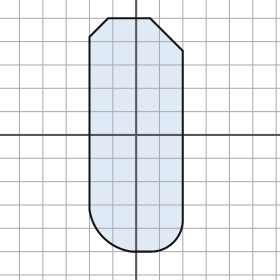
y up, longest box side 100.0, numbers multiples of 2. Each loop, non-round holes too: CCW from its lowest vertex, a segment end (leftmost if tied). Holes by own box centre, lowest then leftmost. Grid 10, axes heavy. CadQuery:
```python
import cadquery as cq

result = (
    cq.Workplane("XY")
    .moveTo(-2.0, -50.0)
    .lineTo(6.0, -50.0)
    .threePointArc((16.0, -46.0), (20.0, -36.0))
    .lineTo(20.0, 36.0)
    .lineTo(6.0, 50.0)
    .lineTo(-12.0, 50.0)
    .lineTo(-20.0, 42.0)
    .lineTo(-20.0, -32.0)
    .threePointArc((-14.0, -44.0), (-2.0, -50.0))
    .close()
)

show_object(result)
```